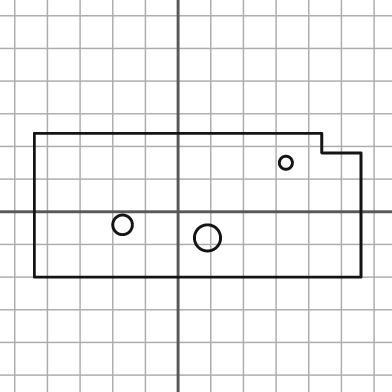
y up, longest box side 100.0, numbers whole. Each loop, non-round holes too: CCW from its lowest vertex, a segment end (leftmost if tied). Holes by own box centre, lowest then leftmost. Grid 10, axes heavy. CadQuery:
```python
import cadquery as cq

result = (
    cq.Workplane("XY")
    .moveTo(-44.0, -20.0)
    .lineTo(56.0, -20.0)
    .lineTo(56.0, 18.0)
    .lineTo(44.0, 18.0)
    .lineTo(44.0, 24.0)
    .lineTo(-44.0, 24.0)
    .close()
    .moveTo(9.0, -8.0)
    .circle(4.0)
    .moveTo(-17.0, -4.0)
    .circle(3.0)
    .moveTo(33.0, 15.0)
    .circle(2.0)
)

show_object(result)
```